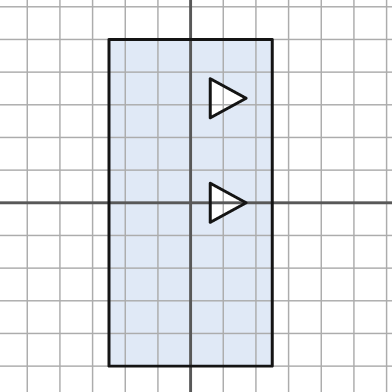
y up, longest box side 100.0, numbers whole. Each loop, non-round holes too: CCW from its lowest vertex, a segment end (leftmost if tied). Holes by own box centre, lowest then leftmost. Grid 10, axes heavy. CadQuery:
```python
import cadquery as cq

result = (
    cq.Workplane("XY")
    .moveTo(-25.0, -50.0)
    .lineTo(25.0, -50.0)
    .lineTo(25.0, 50.0)
    .lineTo(-25.0, 50.0)
    .close()
    .moveTo(6.0, -6.0)
    .lineTo(17.0, 0.0)
    .lineTo(6.0, 6.0)
    .close()
    .moveTo(6.0, 26.0)
    .lineTo(17.0, 32.0)
    .lineTo(6.0, 38.0)
    .close()
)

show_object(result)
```